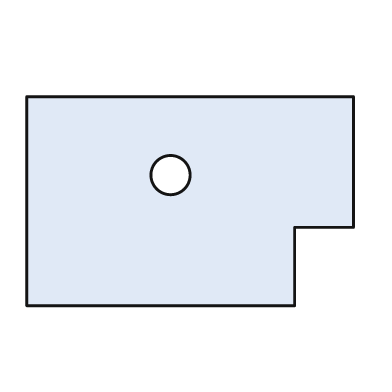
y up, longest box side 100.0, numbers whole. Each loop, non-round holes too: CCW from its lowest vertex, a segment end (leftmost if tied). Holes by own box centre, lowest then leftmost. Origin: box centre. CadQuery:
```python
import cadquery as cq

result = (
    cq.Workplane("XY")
    .moveTo(-50.0, -32.0)
    .lineTo(32.0, -32.0)
    .lineTo(32.0, -8.0)
    .lineTo(50.0, -8.0)
    .lineTo(50.0, 32.0)
    .lineTo(-50.0, 32.0)
    .close()
    .moveTo(-6.0, 8.0)
    .circle(6.0)
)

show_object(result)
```